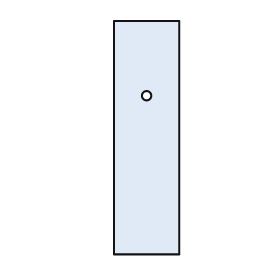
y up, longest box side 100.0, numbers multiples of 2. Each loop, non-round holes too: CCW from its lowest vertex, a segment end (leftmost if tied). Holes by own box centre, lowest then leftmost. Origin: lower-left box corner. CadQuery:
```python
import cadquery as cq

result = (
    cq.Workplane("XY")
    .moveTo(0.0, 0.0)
    .lineTo(28.0, 0.0)
    .lineTo(28.0, 100.0)
    .lineTo(0.0, 100.0)
    .close()
    .moveTo(14.0, 68.0)
    .circle(2.0)
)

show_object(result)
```